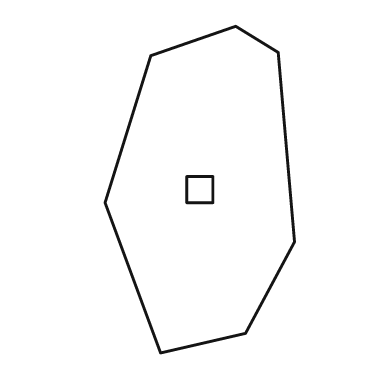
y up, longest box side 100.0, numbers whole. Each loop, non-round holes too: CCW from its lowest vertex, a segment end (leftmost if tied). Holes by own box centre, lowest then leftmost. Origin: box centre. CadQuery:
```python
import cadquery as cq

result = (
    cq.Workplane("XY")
    .moveTo(-12.0, -50.0)
    .lineTo(14.0, -44.0)
    .lineTo(29.0, -16.0)
    .lineTo(24.0, 42.0)
    .lineTo(11.0, 50.0)
    .lineTo(-15.0, 41.0)
    .lineTo(-29.0, -4.0)
    .close()
    .moveTo(-4.0, -4.0)
    .lineTo(4.0, -4.0)
    .lineTo(4.0, 4.0)
    .lineTo(-4.0, 4.0)
    .close()
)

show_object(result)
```